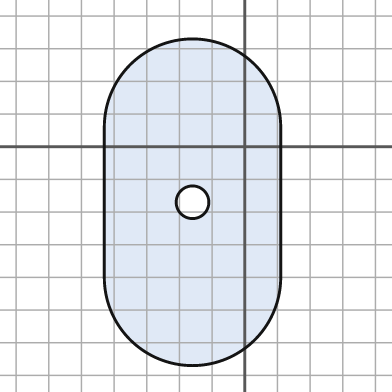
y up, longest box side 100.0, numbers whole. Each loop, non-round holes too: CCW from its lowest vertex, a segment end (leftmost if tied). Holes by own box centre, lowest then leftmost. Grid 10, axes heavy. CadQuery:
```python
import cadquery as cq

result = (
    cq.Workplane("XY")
    .moveTo(-43.0, -40.0)
    .threePointArc((-16.0, -67.0), (11.0, -40.0))
    .lineTo(11.0, 6.0)
    .threePointArc((-16.0, 33.0), (-43.0, 6.0))
    .close()
    .moveTo(-16.0, -17.0)
    .circle(5.0)
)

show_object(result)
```